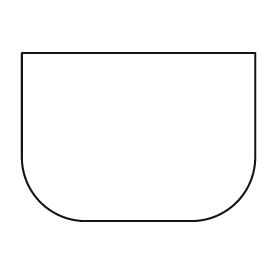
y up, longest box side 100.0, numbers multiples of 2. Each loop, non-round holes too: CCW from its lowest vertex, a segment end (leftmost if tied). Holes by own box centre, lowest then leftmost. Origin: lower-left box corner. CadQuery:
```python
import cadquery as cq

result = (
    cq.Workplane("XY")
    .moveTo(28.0, 0.0)
    .lineTo(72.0, 0.0)
    .threePointArc((92.0, 8.0), (100.0, 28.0))
    .lineTo(100.0, 72.0)
    .lineTo(0.0, 72.0)
    .lineTo(0.0, 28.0)
    .threePointArc((8.0, 8.0), (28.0, 0.0))
    .close()
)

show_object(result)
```